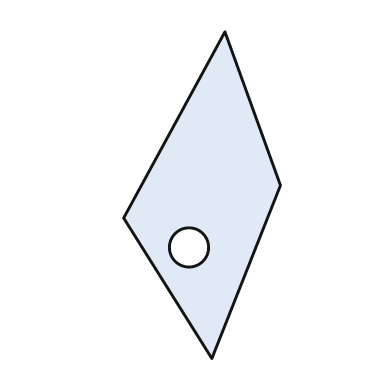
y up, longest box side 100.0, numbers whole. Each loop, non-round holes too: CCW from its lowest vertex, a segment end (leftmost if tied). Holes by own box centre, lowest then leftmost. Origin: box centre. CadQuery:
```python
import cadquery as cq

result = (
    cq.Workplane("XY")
    .moveTo(3.0, -50.0)
    .lineTo(24.0, 3.0)
    .lineTo(7.0, 50.0)
    .lineTo(-24.0, -7.0)
    .close()
    .moveTo(-4.0, -16.0)
    .circle(6.0)
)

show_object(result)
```